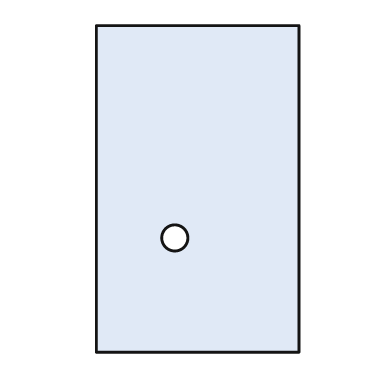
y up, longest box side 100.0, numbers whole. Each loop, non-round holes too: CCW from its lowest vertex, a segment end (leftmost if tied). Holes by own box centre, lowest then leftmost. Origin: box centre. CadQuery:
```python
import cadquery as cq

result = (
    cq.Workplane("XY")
    .moveTo(-31.0, -50.0)
    .lineTo(31.0, -50.0)
    .lineTo(31.0, 50.0)
    .lineTo(-31.0, 50.0)
    .close()
    .moveTo(-7.0, -15.0)
    .circle(4.0)
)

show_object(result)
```